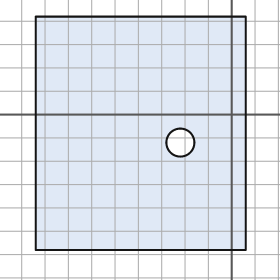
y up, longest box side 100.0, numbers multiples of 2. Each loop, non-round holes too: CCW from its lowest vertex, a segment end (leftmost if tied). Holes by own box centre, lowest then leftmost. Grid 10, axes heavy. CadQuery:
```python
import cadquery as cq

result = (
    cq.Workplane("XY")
    .moveTo(-84.0, -58.0)
    .lineTo(6.0, -58.0)
    .lineTo(6.0, 42.0)
    .lineTo(-84.0, 42.0)
    .close()
    .moveTo(-22.0, -12.0)
    .circle(6.0)
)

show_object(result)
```